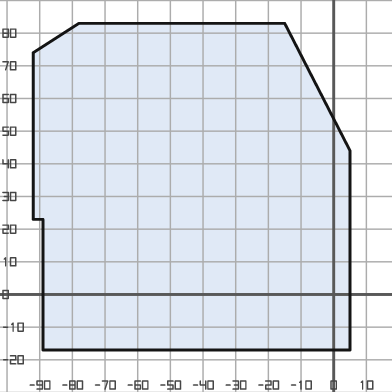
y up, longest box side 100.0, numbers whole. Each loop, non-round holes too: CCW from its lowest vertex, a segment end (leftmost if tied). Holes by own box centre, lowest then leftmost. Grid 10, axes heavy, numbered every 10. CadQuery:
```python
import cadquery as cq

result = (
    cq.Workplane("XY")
    .moveTo(-89.0, -17.0)
    .lineTo(5.0, -17.0)
    .lineTo(5.0, 44.0)
    .lineTo(-15.0, 83.0)
    .lineTo(-78.0, 83.0)
    .lineTo(-92.0, 74.0)
    .lineTo(-92.0, 23.0)
    .lineTo(-89.0, 23.0)
    .close()
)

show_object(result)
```